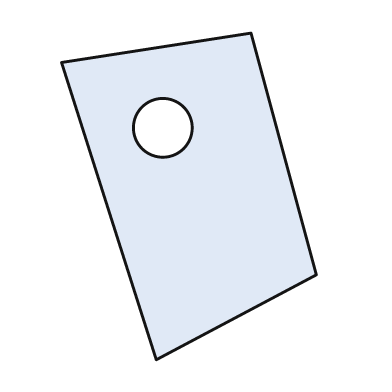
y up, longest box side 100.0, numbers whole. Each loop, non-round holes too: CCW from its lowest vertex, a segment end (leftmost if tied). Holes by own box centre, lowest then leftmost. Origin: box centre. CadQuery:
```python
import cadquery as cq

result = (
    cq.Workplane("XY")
    .moveTo(-10.0, -50.0)
    .lineTo(39.0, -24.0)
    .lineTo(19.0, 50.0)
    .lineTo(-39.0, 41.0)
    .close()
    .moveTo(-8.0, 21.0)
    .circle(9.0)
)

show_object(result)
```